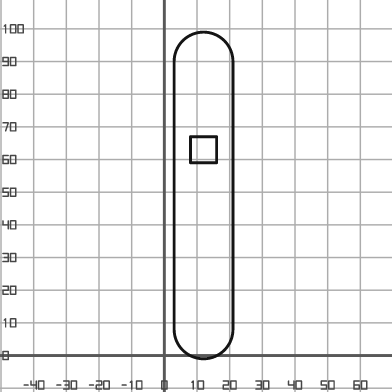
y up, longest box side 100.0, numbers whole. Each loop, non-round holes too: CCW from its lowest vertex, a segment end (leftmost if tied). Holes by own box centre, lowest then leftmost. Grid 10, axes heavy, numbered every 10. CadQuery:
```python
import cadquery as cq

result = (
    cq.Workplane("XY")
    .moveTo(3.0, 8.0)
    .threePointArc((12.0, -1.0), (21.0, 8.0))
    .lineTo(21.0, 90.0)
    .threePointArc((12.0, 99.0), (3.0, 90.0))
    .close()
    .moveTo(8.0, 59.0)
    .lineTo(16.0, 59.0)
    .lineTo(16.0, 67.0)
    .lineTo(8.0, 67.0)
    .close()
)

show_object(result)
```